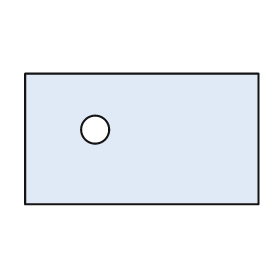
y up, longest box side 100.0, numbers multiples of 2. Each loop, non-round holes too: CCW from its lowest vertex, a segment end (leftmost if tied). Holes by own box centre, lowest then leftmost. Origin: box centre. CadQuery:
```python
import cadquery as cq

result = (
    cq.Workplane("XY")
    .moveTo(-50.0, -28.0)
    .lineTo(50.0, -28.0)
    .lineTo(50.0, 28.0)
    .lineTo(-50.0, 28.0)
    .close()
    .moveTo(-20.0, 4.0)
    .circle(6.0)
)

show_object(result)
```